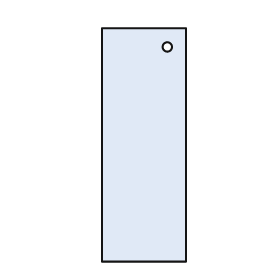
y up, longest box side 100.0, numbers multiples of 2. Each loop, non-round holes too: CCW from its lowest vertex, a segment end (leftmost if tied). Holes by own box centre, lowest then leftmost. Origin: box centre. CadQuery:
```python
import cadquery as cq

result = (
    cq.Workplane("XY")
    .moveTo(-18.0, -50.0)
    .lineTo(18.0, -50.0)
    .lineTo(18.0, 50.0)
    .lineTo(-18.0, 50.0)
    .close()
    .moveTo(10.0, 42.0)
    .circle(2.0)
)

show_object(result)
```